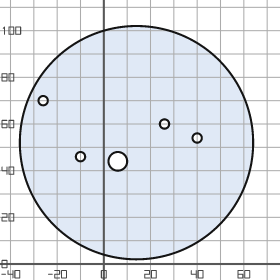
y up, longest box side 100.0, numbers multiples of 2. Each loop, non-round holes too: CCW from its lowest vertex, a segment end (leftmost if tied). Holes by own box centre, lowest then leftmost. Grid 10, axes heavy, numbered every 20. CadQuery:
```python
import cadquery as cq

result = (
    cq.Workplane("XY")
    .moveTo(14.0, 52.0)
    .circle(50.0)
    .moveTo(6.0, 44.0)
    .circle(4.0)
    .moveTo(-10.0, 46.0)
    .circle(2.0)
    .moveTo(40.0, 54.0)
    .circle(2.0)
    .moveTo(26.0, 60.0)
    .circle(2.0)
    .moveTo(-26.0, 70.0)
    .circle(2.0)
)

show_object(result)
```